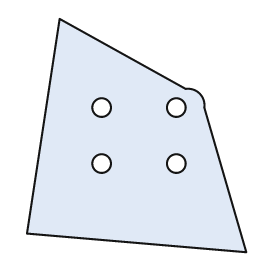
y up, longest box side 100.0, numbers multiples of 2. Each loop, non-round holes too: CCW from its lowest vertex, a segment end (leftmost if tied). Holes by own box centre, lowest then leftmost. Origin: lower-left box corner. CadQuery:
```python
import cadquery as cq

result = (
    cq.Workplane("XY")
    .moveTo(94.0, 0.0)
    .lineTo(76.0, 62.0)
    .threePointArc((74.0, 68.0), (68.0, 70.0))
    .lineTo(14.0, 100.0)
    .lineTo(0.0, 8.0)
    .close()
    .moveTo(32.0, 38.0)
    .circle(4.0)
    .moveTo(64.0, 38.0)
    .circle(4.0)
    .moveTo(32.0, 62.0)
    .circle(4.0)
    .moveTo(64.0, 62.0)
    .circle(4.0)
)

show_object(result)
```